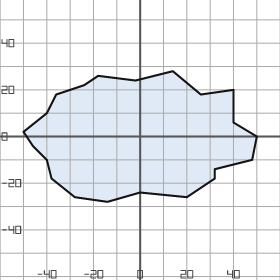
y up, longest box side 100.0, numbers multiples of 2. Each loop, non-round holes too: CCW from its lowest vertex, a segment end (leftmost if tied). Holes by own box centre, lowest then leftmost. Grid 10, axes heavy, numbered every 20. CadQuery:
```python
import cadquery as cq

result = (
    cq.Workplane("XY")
    .moveTo(-14.0, -28.0)
    .lineTo(0.0, -24.0)
    .lineTo(20.0, -26.0)
    .lineTo(32.0, -18.0)
    .lineTo(32.0, -14.0)
    .lineTo(48.0, -10.0)
    .lineTo(50.0, 0.0)
    .lineTo(40.0, 6.0)
    .lineTo(40.0, 20.0)
    .lineTo(26.0, 18.0)
    .lineTo(14.0, 28.0)
    .lineTo(-2.0, 24.0)
    .lineTo(-18.0, 26.0)
    .lineTo(-24.0, 22.0)
    .lineTo(-36.0, 18.0)
    .lineTo(-40.0, 10.0)
    .lineTo(-50.0, 2.0)
    .lineTo(-46.0, -4.0)
    .lineTo(-40.0, -10.0)
    .lineTo(-38.0, -18.0)
    .lineTo(-28.0, -26.0)
    .close()
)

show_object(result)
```